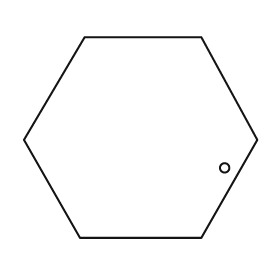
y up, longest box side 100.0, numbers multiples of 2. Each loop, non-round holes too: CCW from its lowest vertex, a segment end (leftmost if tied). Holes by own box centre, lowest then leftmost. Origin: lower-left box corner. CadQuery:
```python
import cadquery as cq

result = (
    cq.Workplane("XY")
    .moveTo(24.0, 0.0)
    .lineTo(76.0, 0.0)
    .lineTo(100.0, 42.0)
    .lineTo(76.0, 86.0)
    .lineTo(26.0, 86.0)
    .lineTo(0.0, 42.0)
    .close()
    .moveTo(86.0, 30.0)
    .circle(2.0)
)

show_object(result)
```